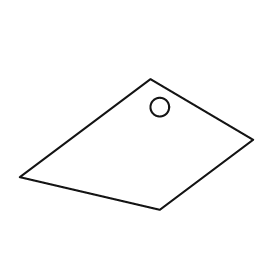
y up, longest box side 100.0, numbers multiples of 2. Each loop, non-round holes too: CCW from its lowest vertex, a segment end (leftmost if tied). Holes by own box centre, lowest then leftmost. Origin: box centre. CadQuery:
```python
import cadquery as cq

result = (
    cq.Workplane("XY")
    .moveTo(10.0, -28.0)
    .lineTo(50.0, 2.0)
    .lineTo(6.0, 28.0)
    .lineTo(-50.0, -14.0)
    .close()
    .moveTo(10.0, 16.0)
    .circle(4.0)
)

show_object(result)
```